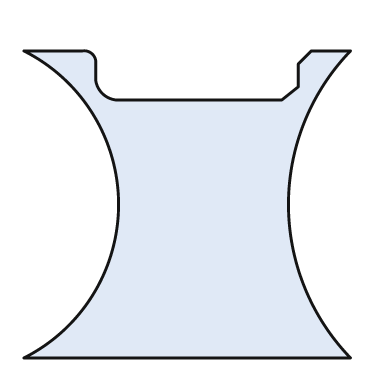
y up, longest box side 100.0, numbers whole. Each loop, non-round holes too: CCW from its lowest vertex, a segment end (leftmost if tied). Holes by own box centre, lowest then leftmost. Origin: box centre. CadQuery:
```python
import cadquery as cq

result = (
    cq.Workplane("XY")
    .moveTo(-50.0, -47.0)
    .lineTo(50.0, -47.0)
    .threePointArc((31.0, 0.0), (50.0, 47.0))
    .lineTo(38.0, 47.0)
    .lineTo(34.0, 43.0)
    .lineTo(34.0, 36.0)
    .lineTo(29.0, 32.0)
    .lineTo(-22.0, 32.0)
    .threePointArc((-26.0, 34.0), (-28.0, 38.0))
    .lineTo(-28.0, 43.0)
    .threePointArc((-29.0, 46.0), (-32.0, 47.0))
    .lineTo(-50.0, 47.0)
    .threePointArc((-21.0, 0.0), (-50.0, -47.0))
    .close()
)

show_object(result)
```